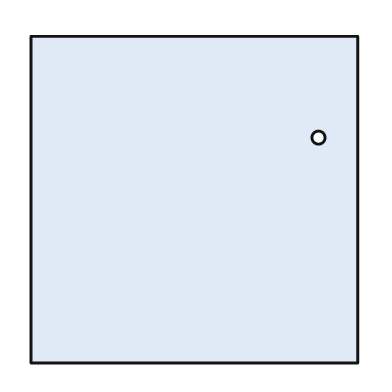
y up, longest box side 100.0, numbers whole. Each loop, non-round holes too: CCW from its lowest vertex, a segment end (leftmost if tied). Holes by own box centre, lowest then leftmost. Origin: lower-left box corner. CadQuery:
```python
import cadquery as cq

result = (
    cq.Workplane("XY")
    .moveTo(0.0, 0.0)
    .lineTo(100.0, 0.0)
    .lineTo(100.0, 100.0)
    .lineTo(0.0, 100.0)
    .close()
    .moveTo(88.0, 69.0)
    .circle(2.0)
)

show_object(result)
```